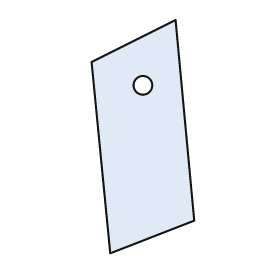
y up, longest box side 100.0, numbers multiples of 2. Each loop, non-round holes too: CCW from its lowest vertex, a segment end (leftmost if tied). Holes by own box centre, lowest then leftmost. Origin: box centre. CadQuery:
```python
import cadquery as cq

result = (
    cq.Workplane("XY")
    .moveTo(-14.0, -50.0)
    .lineTo(22.0, -36.0)
    .lineTo(14.0, 50.0)
    .lineTo(-22.0, 32.0)
    .close()
    .moveTo(0.0, 22.0)
    .circle(4.0)
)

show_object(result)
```